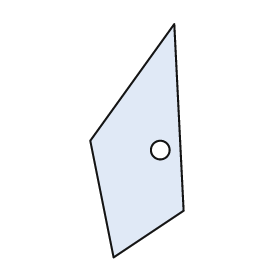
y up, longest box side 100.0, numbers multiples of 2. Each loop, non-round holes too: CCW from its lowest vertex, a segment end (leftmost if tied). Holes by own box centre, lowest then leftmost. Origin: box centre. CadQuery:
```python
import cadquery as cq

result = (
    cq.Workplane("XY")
    .moveTo(-10.0, -50.0)
    .lineTo(20.0, -30.0)
    .lineTo(16.0, 50.0)
    .lineTo(-20.0, 0.0)
    .close()
    .moveTo(10.0, -4.0)
    .circle(4.0)
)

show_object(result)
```